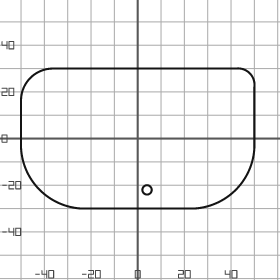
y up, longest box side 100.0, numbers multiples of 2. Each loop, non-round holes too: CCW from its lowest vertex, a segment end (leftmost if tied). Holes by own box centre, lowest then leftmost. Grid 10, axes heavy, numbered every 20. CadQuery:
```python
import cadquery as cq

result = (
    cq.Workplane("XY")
    .moveTo(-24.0, -30.0)
    .lineTo(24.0, -30.0)
    .threePointArc((42.0, -22.0), (50.0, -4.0))
    .lineTo(50.0, 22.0)
    .threePointArc((48.0, 28.0), (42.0, 30.0))
    .lineTo(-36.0, 30.0)
    .threePointArc((-46.0, 26.0), (-50.0, 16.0))
    .lineTo(-50.0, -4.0)
    .threePointArc((-42.0, -22.0), (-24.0, -30.0))
    .close()
    .moveTo(4.0, -22.0)
    .circle(2.0)
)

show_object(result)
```